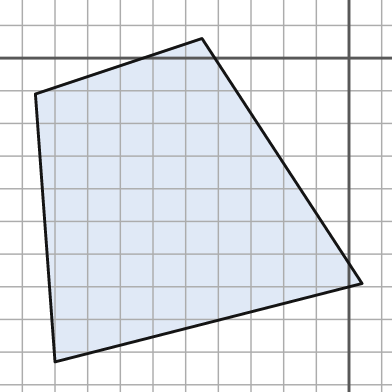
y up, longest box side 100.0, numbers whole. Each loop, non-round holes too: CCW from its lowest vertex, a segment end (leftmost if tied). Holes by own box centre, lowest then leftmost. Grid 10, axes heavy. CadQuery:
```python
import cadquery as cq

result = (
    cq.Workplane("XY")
    .moveTo(-90.0, -93.0)
    .lineTo(4.0, -69.0)
    .lineTo(-45.0, 6.0)
    .lineTo(-96.0, -11.0)
    .close()
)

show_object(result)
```